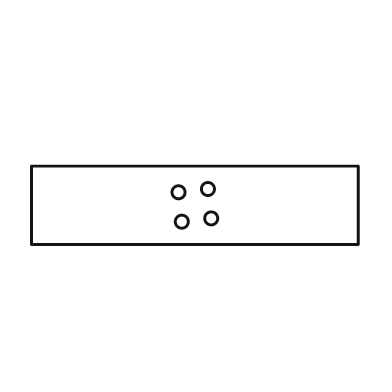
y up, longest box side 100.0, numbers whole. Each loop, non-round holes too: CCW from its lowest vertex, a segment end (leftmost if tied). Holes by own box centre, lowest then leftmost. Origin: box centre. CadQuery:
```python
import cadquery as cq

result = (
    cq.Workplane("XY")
    .moveTo(-50.0, -12.0)
    .lineTo(50.0, -12.0)
    .lineTo(50.0, 12.0)
    .lineTo(-50.0, 12.0)
    .close()
    .moveTo(-4.0, -5.0)
    .circle(2.0)
    .moveTo(5.0, -4.0)
    .circle(2.0)
    .moveTo(-5.0, 4.0)
    .circle(2.0)
    .moveTo(4.0, 5.0)
    .circle(2.0)
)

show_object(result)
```